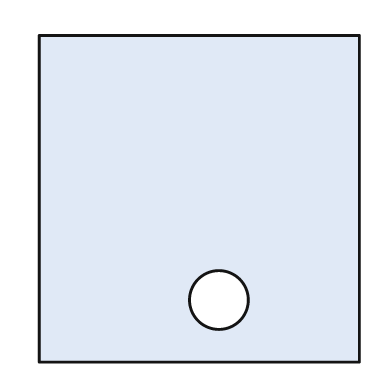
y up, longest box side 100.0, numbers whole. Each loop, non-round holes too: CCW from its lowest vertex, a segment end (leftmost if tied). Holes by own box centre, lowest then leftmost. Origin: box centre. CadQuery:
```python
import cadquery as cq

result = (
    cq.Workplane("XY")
    .moveTo(-49.0, -50.0)
    .lineTo(49.0, -50.0)
    .lineTo(49.0, 50.0)
    .lineTo(-49.0, 50.0)
    .close()
    .moveTo(6.0, -31.0)
    .circle(9.0)
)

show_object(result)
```